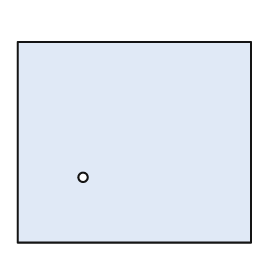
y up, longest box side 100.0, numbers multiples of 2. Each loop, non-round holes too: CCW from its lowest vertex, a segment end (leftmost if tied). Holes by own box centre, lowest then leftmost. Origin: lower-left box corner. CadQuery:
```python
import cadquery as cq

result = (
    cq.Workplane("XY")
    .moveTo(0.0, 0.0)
    .lineTo(100.0, 0.0)
    .lineTo(100.0, 86.0)
    .lineTo(0.0, 86.0)
    .close()
    .moveTo(28.0, 28.0)
    .circle(2.0)
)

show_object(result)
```